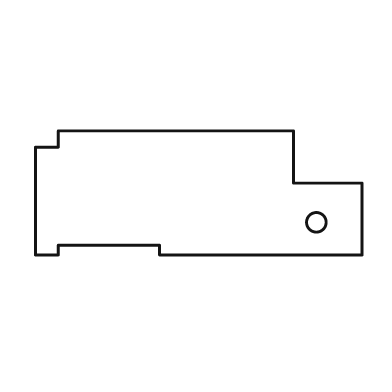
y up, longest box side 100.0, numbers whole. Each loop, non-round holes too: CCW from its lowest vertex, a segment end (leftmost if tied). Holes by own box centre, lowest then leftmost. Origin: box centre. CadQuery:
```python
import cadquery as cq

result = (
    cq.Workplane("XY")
    .moveTo(-50.0, -19.0)
    .lineTo(-43.0, -19.0)
    .lineTo(-43.0, -16.0)
    .lineTo(-12.0, -16.0)
    .lineTo(-12.0, -19.0)
    .lineTo(50.0, -19.0)
    .lineTo(50.0, 3.0)
    .lineTo(29.0, 3.0)
    .lineTo(29.0, 19.0)
    .lineTo(-43.0, 19.0)
    .lineTo(-43.0, 14.0)
    .lineTo(-50.0, 14.0)
    .close()
    .moveTo(36.0, -9.0)
    .circle(3.0)
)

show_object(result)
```